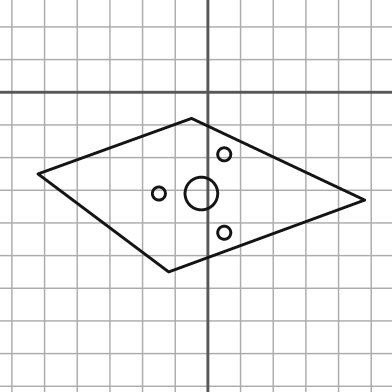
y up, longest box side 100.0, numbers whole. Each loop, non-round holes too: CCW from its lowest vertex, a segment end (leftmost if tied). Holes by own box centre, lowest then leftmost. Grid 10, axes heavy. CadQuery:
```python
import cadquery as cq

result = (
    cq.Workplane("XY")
    .moveTo(-12.0, -55.0)
    .lineTo(48.0, -33.0)
    .lineTo(-5.0, -8.0)
    .lineTo(-52.0, -25.0)
    .close()
    .moveTo(5.0, -43.0)
    .circle(2.0)
    .moveTo(-15.0, -31.0)
    .circle(2.0)
    .moveTo(-2.0, -31.0)
    .circle(5.0)
    .moveTo(5.0, -19.0)
    .circle(2.0)
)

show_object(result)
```